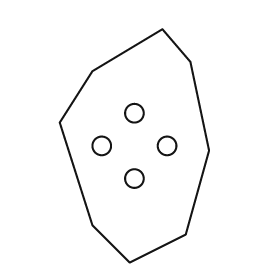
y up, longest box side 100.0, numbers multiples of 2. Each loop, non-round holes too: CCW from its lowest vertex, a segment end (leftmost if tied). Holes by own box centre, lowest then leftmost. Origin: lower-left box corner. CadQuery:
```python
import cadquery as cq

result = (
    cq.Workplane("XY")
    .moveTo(30.0, 0.0)
    .lineTo(54.0, 12.0)
    .lineTo(64.0, 48.0)
    .lineTo(56.0, 86.0)
    .lineTo(44.0, 100.0)
    .lineTo(14.0, 82.0)
    .lineTo(0.0, 60.0)
    .lineTo(14.0, 16.0)
    .close()
    .moveTo(32.0, 36.0)
    .circle(4.0)
    .moveTo(18.0, 50.0)
    .circle(4.0)
    .moveTo(46.0, 50.0)
    .circle(4.0)
    .moveTo(32.0, 64.0)
    .circle(4.0)
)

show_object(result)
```